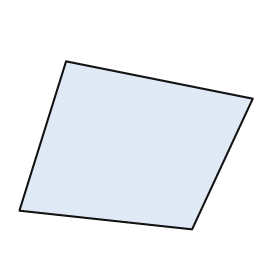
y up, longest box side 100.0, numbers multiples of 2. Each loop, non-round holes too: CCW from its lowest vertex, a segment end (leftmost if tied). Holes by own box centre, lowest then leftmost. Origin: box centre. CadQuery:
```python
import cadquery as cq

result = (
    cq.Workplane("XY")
    .moveTo(24.0, -36.0)
    .lineTo(50.0, 20.0)
    .lineTo(-30.0, 36.0)
    .lineTo(-50.0, -28.0)
    .close()
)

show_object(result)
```